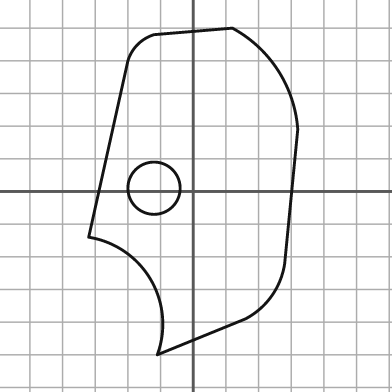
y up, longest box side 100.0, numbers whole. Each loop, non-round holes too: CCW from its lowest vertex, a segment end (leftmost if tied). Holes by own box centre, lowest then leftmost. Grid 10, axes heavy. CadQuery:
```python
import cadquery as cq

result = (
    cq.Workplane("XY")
    .moveTo(-11.0, -50.0)
    .lineTo(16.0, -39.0)
    .threePointArc((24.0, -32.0), (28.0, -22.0))
    .lineTo(32.0, 19.0)
    .threePointArc((26.0, 37.0), (12.0, 50.0))
    .lineTo(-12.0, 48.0)
    .threePointArc((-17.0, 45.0), (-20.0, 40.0))
    .lineTo(-32.0, -14.0)
    .threePointArc((-13.0, -27.0), (-11.0, -50.0))
    .close()
    .moveTo(-12.0, 1.0)
    .circle(8.0)
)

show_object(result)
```